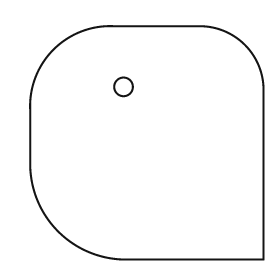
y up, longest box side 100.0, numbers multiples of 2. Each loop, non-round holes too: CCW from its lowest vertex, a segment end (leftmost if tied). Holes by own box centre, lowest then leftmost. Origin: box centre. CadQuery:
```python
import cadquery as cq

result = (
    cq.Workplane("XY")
    .moveTo(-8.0, -50.0)
    .lineTo(50.0, -50.0)
    .lineTo(50.0, 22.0)
    .threePointArc((42.0, 42.0), (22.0, 50.0))
    .lineTo(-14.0, 50.0)
    .threePointArc((-40.0, 40.0), (-50.0, 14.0))
    .lineTo(-50.0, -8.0)
    .threePointArc((-38.0, -38.0), (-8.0, -50.0))
    .close()
    .moveTo(-10.0, 24.0)
    .circle(4.0)
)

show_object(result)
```